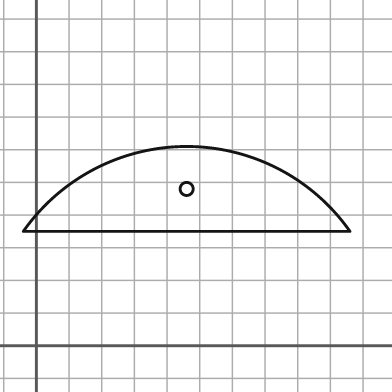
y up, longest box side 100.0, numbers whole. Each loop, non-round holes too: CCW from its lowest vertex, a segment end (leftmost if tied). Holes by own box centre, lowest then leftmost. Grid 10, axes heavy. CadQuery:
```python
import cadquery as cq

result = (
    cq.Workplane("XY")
    .moveTo(-4.0, 35.0)
    .lineTo(96.0, 35.0)
    .threePointArc((46.0, 61.0), (-4.0, 35.0))
    .close()
    .moveTo(46.0, 48.0)
    .circle(2.0)
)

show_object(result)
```